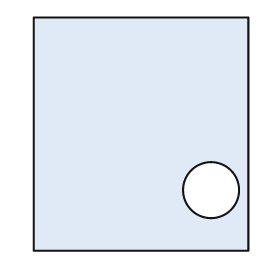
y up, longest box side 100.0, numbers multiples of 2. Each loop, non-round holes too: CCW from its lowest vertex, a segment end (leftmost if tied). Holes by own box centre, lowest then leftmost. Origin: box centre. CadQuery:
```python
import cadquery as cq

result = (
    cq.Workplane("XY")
    .moveTo(-46.0, -50.0)
    .lineTo(46.0, -50.0)
    .lineTo(46.0, 50.0)
    .lineTo(-46.0, 50.0)
    .close()
    .moveTo(30.0, -24.0)
    .circle(12.0)
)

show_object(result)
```